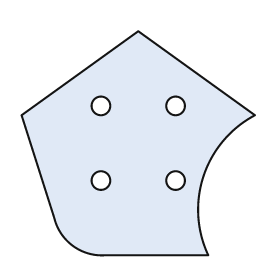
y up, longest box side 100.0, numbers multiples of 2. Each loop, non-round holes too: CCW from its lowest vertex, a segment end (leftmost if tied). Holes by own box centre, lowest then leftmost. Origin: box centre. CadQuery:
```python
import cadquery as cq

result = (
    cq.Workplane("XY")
    .moveTo(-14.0, -48.0)
    .lineTo(30.0, -48.0)
    .threePointArc((28.0, -14.0), (50.0, 12.0))
    .lineTo(0.0, 48.0)
    .lineTo(-50.0, 12.0)
    .lineTo(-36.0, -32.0)
    .threePointArc((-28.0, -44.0), (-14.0, -48.0))
    .close()
    .moveTo(-16.0, -16.0)
    .circle(4.0)
    .moveTo(16.0, -16.0)
    .circle(4.0)
    .moveTo(-16.0, 16.0)
    .circle(4.0)
    .moveTo(16.0, 16.0)
    .circle(4.0)
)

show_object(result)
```